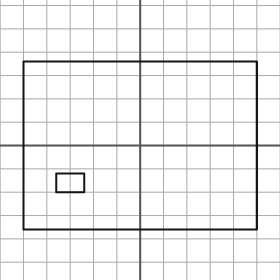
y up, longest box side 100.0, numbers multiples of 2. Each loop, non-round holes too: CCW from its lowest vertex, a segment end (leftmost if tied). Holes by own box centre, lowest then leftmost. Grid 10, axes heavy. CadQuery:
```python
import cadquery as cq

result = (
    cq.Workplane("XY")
    .moveTo(-50.0, -36.0)
    .lineTo(50.0, -36.0)
    .lineTo(50.0, 36.0)
    .lineTo(-50.0, 36.0)
    .close()
    .moveTo(-36.0, -20.0)
    .lineTo(-24.0, -20.0)
    .lineTo(-24.0, -12.0)
    .lineTo(-36.0, -12.0)
    .close()
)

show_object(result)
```